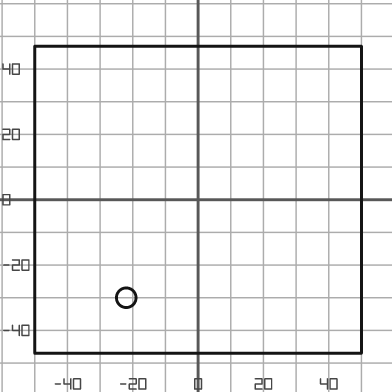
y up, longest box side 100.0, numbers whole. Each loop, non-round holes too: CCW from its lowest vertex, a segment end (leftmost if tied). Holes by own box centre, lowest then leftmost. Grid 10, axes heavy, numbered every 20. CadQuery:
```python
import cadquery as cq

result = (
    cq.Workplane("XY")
    .moveTo(-50.0, -47.0)
    .lineTo(50.0, -47.0)
    .lineTo(50.0, 47.0)
    .lineTo(-50.0, 47.0)
    .close()
    .moveTo(-22.0, -30.0)
    .circle(3.0)
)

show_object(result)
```